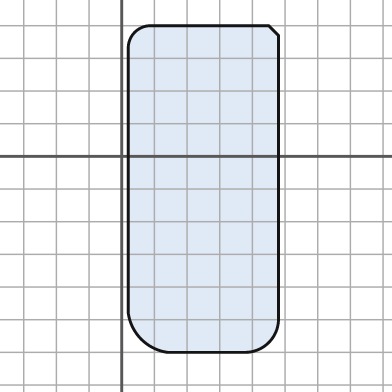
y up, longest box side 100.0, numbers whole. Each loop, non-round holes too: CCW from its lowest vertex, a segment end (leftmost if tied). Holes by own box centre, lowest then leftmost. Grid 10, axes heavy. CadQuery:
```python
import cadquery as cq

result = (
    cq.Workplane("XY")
    .moveTo(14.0, -60.0)
    .lineTo(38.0, -60.0)
    .threePointArc((45.0, -57.0), (48.0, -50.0))
    .lineTo(48.0, 37.0)
    .lineTo(45.0, 40.0)
    .lineTo(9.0, 40.0)
    .threePointArc((4.0, 38.0), (2.0, 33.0))
    .lineTo(2.0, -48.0)
    .threePointArc((6.0, -56.0), (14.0, -60.0))
    .close()
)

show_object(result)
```